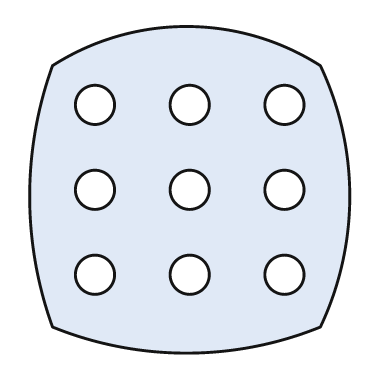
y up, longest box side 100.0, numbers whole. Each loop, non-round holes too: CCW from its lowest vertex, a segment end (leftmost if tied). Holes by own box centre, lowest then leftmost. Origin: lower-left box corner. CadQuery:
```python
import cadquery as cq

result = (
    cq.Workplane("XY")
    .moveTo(7.0, 8.0)
    .threePointArc((48.0, 0.0), (89.0, 8.0))
    .threePointArc((98.0, 48.0), (89.0, 88.0))
    .threePointArc((48.0, 100.0), (7.0, 88.0))
    .threePointArc((0.0, 48.0), (7.0, 8.0))
    .close()
    .moveTo(20.0, 24.0)
    .circle(6.0)
    .moveTo(49.0, 24.0)
    .circle(6.0)
    .moveTo(78.0, 24.0)
    .circle(6.0)
    .moveTo(20.0, 50.0)
    .circle(6.0)
    .moveTo(49.0, 50.0)
    .circle(6.0)
    .moveTo(78.0, 50.0)
    .circle(6.0)
    .moveTo(20.0, 76.0)
    .circle(6.0)
    .moveTo(49.0, 76.0)
    .circle(6.0)
    .moveTo(78.0, 76.0)
    .circle(6.0)
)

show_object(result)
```